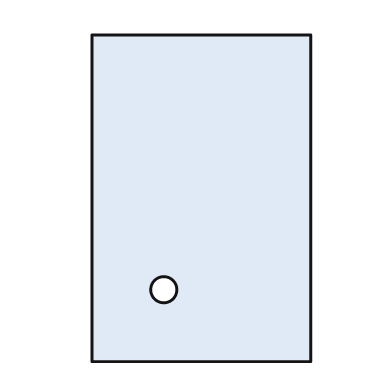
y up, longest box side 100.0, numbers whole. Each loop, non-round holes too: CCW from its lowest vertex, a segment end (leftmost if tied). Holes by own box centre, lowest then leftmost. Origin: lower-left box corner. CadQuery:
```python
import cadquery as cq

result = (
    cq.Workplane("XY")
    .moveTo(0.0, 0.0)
    .lineTo(67.0, 0.0)
    .lineTo(67.0, 100.0)
    .lineTo(0.0, 100.0)
    .close()
    .moveTo(22.0, 22.0)
    .circle(4.0)
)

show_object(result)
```